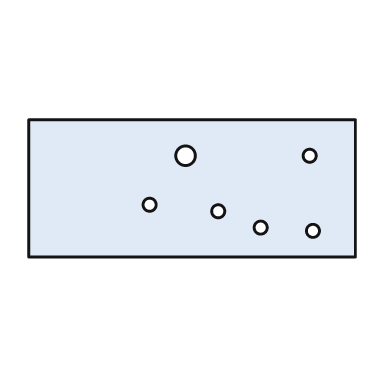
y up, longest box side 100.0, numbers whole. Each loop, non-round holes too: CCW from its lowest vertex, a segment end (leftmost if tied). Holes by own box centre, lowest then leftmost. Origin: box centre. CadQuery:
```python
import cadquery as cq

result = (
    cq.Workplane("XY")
    .moveTo(-50.0, -21.0)
    .lineTo(50.0, -21.0)
    .lineTo(50.0, 21.0)
    .lineTo(-50.0, 21.0)
    .close()
    .moveTo(37.0, -13.0)
    .circle(2.0)
    .moveTo(21.0, -12.0)
    .circle(2.0)
    .moveTo(8.0, -7.0)
    .circle(2.0)
    .moveTo(-13.0, -5.0)
    .circle(2.0)
    .moveTo(-2.0, 10.0)
    .circle(3.0)
    .moveTo(36.0, 10.0)
    .circle(2.0)
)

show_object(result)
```